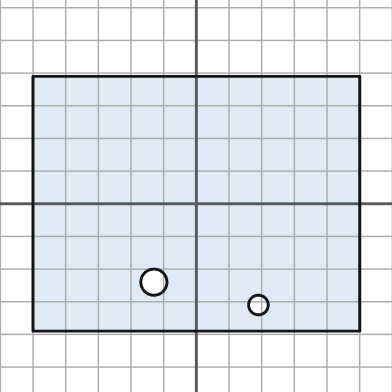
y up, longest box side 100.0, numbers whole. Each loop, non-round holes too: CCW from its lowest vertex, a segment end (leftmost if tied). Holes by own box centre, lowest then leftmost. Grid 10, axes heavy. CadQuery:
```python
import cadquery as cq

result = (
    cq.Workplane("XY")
    .moveTo(-50.0, -39.0)
    .lineTo(50.0, -39.0)
    .lineTo(50.0, 39.0)
    .lineTo(-50.0, 39.0)
    .close()
    .moveTo(19.0, -31.0)
    .circle(3.0)
    .moveTo(-13.0, -24.0)
    .circle(4.0)
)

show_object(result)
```